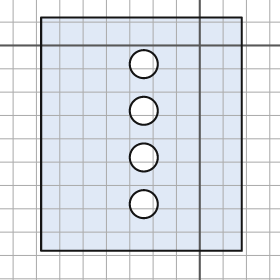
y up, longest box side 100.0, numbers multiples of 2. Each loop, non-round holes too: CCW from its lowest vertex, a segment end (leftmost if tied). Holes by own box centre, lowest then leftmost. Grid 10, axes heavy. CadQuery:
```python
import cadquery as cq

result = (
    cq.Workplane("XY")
    .moveTo(-68.0, -88.0)
    .lineTo(18.0, -88.0)
    .lineTo(18.0, 12.0)
    .lineTo(-68.0, 12.0)
    .close()
    .moveTo(-24.0, -68.0)
    .circle(6.0)
    .moveTo(-24.0, -48.0)
    .circle(6.0)
    .moveTo(-24.0, -28.0)
    .circle(6.0)
    .moveTo(-24.0, -8.0)
    .circle(6.0)
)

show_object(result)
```